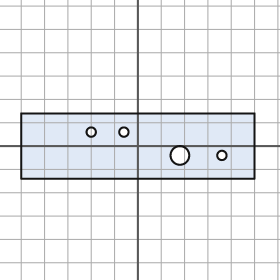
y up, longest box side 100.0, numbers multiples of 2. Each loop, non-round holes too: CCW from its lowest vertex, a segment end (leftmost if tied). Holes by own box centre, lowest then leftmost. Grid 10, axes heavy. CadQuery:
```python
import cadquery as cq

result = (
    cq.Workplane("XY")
    .moveTo(-50.0, -14.0)
    .lineTo(50.0, -14.0)
    .lineTo(50.0, 14.0)
    .lineTo(-50.0, 14.0)
    .close()
    .moveTo(18.0, -4.0)
    .circle(4.0)
    .moveTo(36.0, -4.0)
    .circle(2.0)
    .moveTo(-20.0, 6.0)
    .circle(2.0)
    .moveTo(-6.0, 6.0)
    .circle(2.0)
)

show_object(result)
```